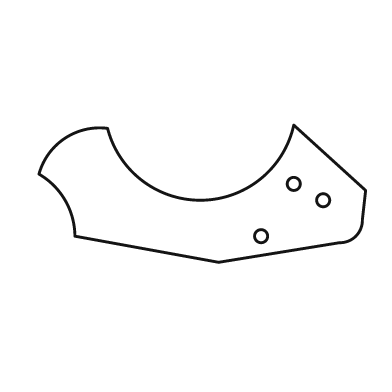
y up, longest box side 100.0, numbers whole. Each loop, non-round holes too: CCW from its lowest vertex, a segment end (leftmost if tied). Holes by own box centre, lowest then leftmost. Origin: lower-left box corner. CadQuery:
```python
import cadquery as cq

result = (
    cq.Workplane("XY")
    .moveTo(55.0, 0.0)
    .lineTo(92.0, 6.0)
    .threePointArc((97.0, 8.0), (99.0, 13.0))
    .lineTo(100.0, 22.0)
    .lineTo(78.0, 42.0)
    .threePointArc((50.0, 19.0), (21.0, 41.0))
    .threePointArc((8.0, 38.0), (0.0, 27.0))
    .threePointArc((8.0, 19.0), (11.0, 8.0))
    .close()
    .moveTo(68.0, 8.0)
    .circle(2.0)
    .moveTo(87.0, 19.0)
    .circle(2.0)
    .moveTo(78.0, 24.0)
    .circle(2.0)
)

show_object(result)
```